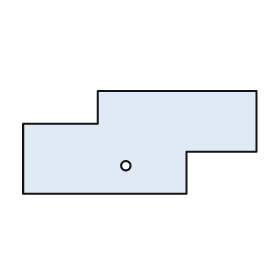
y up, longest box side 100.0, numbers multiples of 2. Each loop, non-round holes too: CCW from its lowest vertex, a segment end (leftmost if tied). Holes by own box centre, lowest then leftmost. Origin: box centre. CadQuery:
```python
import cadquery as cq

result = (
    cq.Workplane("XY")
    .moveTo(-50.0, -22.0)
    .lineTo(20.0, -22.0)
    .lineTo(20.0, -4.0)
    .lineTo(50.0, -4.0)
    .lineTo(50.0, 22.0)
    .lineTo(-18.0, 22.0)
    .lineTo(-18.0, 8.0)
    .lineTo(-50.0, 8.0)
    .close()
    .moveTo(-6.0, -10.0)
    .circle(2.0)
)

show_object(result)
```